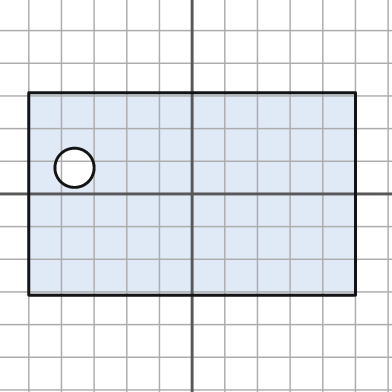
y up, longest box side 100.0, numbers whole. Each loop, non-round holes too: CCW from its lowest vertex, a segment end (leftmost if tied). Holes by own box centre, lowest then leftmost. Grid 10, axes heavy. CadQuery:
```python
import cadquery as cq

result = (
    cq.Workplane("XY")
    .moveTo(-50.0, -31.0)
    .lineTo(50.0, -31.0)
    .lineTo(50.0, 31.0)
    .lineTo(-50.0, 31.0)
    .close()
    .moveTo(-36.0, 8.0)
    .circle(6.0)
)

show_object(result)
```